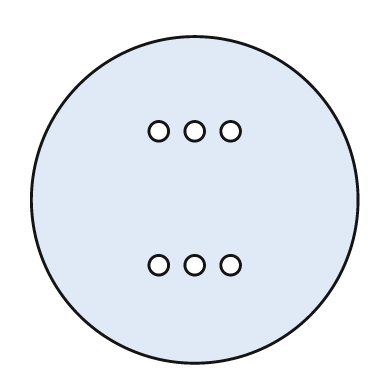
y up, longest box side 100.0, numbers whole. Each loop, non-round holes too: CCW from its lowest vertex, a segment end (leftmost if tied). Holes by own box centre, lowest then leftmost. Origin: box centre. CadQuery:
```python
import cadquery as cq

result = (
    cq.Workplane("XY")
    .moveTo(0.0, 0.0)
    .circle(50.0)
    .moveTo(-11.0, -20.0)
    .circle(3.0)
    .moveTo(0.0, -20.0)
    .circle(3.0)
    .moveTo(11.0, -20.0)
    .circle(3.0)
    .moveTo(-11.0, 21.0)
    .circle(3.0)
    .moveTo(0.0, 21.0)
    .circle(3.0)
    .moveTo(11.0, 21.0)
    .circle(3.0)
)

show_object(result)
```